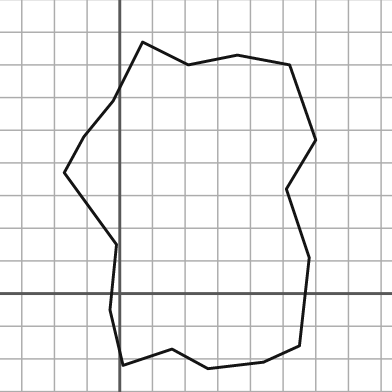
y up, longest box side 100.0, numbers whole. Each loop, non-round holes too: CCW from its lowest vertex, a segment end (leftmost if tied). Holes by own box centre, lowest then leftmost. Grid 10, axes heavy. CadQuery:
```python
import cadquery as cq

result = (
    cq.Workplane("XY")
    .moveTo(27.0, -23.0)
    .lineTo(44.0, -21.0)
    .lineTo(55.0, -16.0)
    .lineTo(58.0, 11.0)
    .lineTo(51.0, 32.0)
    .lineTo(60.0, 47.0)
    .lineTo(52.0, 70.0)
    .lineTo(36.0, 73.0)
    .lineTo(21.0, 70.0)
    .lineTo(7.0, 77.0)
    .lineTo(-2.0, 59.0)
    .lineTo(-11.0, 48.0)
    .lineTo(-17.0, 37.0)
    .lineTo(-1.0, 15.0)
    .lineTo(-3.0, -5.0)
    .lineTo(1.0, -22.0)
    .lineTo(16.0, -17.0)
    .close()
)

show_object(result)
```